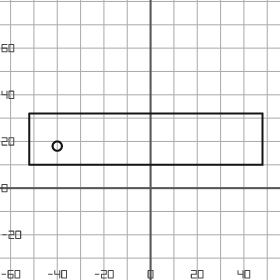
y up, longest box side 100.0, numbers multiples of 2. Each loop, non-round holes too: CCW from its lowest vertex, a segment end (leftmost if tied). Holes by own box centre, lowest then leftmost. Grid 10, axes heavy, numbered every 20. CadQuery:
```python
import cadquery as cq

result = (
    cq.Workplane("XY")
    .moveTo(-52.0, 10.0)
    .lineTo(48.0, 10.0)
    .lineTo(48.0, 32.0)
    .lineTo(-52.0, 32.0)
    .close()
    .moveTo(-40.0, 18.0)
    .circle(2.0)
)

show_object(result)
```